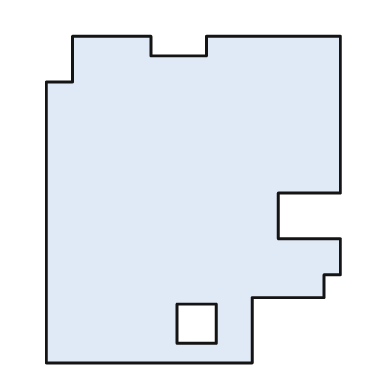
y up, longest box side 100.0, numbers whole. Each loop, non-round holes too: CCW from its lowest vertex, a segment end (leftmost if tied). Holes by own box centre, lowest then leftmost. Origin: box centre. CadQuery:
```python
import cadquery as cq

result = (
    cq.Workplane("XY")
    .moveTo(-45.0, -50.0)
    .lineTo(18.0, -50.0)
    .lineTo(18.0, -30.0)
    .lineTo(40.0, -30.0)
    .lineTo(40.0, -23.0)
    .lineTo(45.0, -23.0)
    .lineTo(45.0, -12.0)
    .lineTo(26.0, -12.0)
    .lineTo(26.0, 2.0)
    .lineTo(45.0, 2.0)
    .lineTo(45.0, 50.0)
    .lineTo(4.0, 50.0)
    .lineTo(4.0, 44.0)
    .lineTo(-13.0, 44.0)
    .lineTo(-13.0, 50.0)
    .lineTo(-37.0, 50.0)
    .lineTo(-37.0, 36.0)
    .lineTo(-45.0, 36.0)
    .close()
    .moveTo(-5.0, -44.0)
    .lineTo(7.0, -44.0)
    .lineTo(7.0, -32.0)
    .lineTo(-5.0, -32.0)
    .close()
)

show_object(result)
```